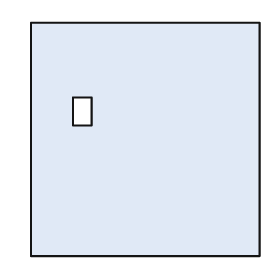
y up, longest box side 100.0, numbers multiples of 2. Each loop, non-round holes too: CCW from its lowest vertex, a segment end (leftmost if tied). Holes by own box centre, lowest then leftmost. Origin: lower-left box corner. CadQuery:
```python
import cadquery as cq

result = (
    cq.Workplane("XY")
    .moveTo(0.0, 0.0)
    .lineTo(98.0, 0.0)
    .lineTo(98.0, 100.0)
    .lineTo(0.0, 100.0)
    .close()
    .moveTo(18.0, 56.0)
    .lineTo(26.0, 56.0)
    .lineTo(26.0, 68.0)
    .lineTo(18.0, 68.0)
    .close()
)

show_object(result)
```